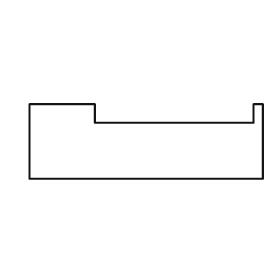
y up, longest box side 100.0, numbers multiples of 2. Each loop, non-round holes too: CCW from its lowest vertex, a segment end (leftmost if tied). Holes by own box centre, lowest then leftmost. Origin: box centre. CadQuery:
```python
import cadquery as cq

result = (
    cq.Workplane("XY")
    .moveTo(-50.0, -16.0)
    .lineTo(50.0, -16.0)
    .lineTo(50.0, 16.0)
    .lineTo(46.0, 16.0)
    .lineTo(46.0, 8.0)
    .lineTo(-22.0, 8.0)
    .lineTo(-22.0, 16.0)
    .lineTo(-50.0, 16.0)
    .close()
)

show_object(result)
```